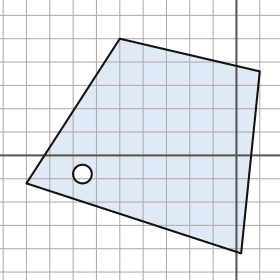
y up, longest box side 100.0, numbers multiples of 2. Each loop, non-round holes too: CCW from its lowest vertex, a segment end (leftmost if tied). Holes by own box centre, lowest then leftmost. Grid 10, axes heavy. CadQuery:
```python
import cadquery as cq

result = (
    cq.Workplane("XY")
    .moveTo(2.0, -42.0)
    .lineTo(10.0, 36.0)
    .lineTo(-50.0, 50.0)
    .lineTo(-90.0, -12.0)
    .close()
    .moveTo(-66.0, -8.0)
    .circle(4.0)
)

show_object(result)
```